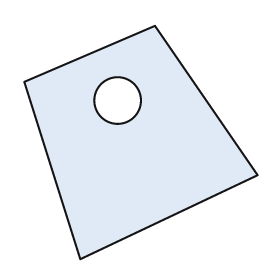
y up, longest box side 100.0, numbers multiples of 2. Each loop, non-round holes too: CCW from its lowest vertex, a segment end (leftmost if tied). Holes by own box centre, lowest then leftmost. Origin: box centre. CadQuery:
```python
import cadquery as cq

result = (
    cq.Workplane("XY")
    .moveTo(-26.0, -50.0)
    .lineTo(50.0, -14.0)
    .lineTo(6.0, 50.0)
    .lineTo(-50.0, 26.0)
    .close()
    .moveTo(-10.0, 18.0)
    .circle(10.0)
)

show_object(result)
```